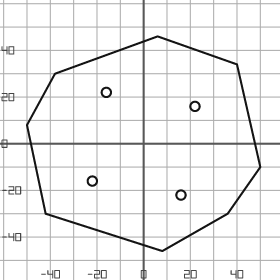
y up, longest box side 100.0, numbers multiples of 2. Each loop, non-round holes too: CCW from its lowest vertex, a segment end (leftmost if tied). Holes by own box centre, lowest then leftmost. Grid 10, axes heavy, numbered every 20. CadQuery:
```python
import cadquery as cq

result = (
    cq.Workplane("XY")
    .moveTo(8.0, -46.0)
    .lineTo(36.0, -30.0)
    .lineTo(50.0, -10.0)
    .lineTo(40.0, 34.0)
    .lineTo(6.0, 46.0)
    .lineTo(-38.0, 30.0)
    .lineTo(-50.0, 8.0)
    .lineTo(-42.0, -30.0)
    .close()
    .moveTo(16.0, -22.0)
    .circle(2.0)
    .moveTo(-22.0, -16.0)
    .circle(2.0)
    .moveTo(22.0, 16.0)
    .circle(2.0)
    .moveTo(-16.0, 22.0)
    .circle(2.0)
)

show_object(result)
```